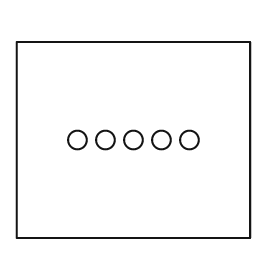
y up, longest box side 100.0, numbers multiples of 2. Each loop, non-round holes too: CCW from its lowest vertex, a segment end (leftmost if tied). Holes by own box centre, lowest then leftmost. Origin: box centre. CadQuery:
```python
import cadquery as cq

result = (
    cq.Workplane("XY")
    .moveTo(-50.0, -42.0)
    .lineTo(50.0, -42.0)
    .lineTo(50.0, 42.0)
    .lineTo(-50.0, 42.0)
    .close()
    .moveTo(-24.0, 0.0)
    .circle(4.0)
    .moveTo(-12.0, 0.0)
    .circle(4.0)
    .moveTo(0.0, 0.0)
    .circle(4.0)
    .moveTo(12.0, 0.0)
    .circle(4.0)
    .moveTo(24.0, 0.0)
    .circle(4.0)
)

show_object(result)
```